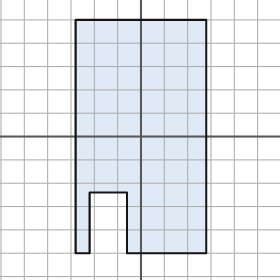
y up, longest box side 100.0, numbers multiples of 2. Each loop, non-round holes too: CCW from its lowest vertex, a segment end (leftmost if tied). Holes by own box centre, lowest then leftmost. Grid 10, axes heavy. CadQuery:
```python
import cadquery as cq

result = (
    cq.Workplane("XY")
    .moveTo(-28.0, -50.0)
    .lineTo(-22.0, -50.0)
    .lineTo(-22.0, -24.0)
    .lineTo(-6.0, -24.0)
    .lineTo(-6.0, -50.0)
    .lineTo(28.0, -50.0)
    .lineTo(28.0, 50.0)
    .lineTo(-28.0, 50.0)
    .close()
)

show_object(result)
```